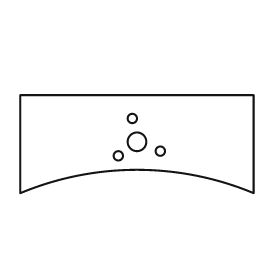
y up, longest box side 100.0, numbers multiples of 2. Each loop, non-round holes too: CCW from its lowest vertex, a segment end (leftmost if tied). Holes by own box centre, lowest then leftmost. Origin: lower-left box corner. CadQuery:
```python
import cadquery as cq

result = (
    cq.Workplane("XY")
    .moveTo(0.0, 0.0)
    .threePointArc((50.0, 10.0), (100.0, 0.0))
    .lineTo(100.0, 42.0)
    .lineTo(0.0, 42.0)
    .close()
    .moveTo(42.0, 16.0)
    .circle(2.0)
    .moveTo(60.0, 18.0)
    .circle(2.0)
    .moveTo(50.0, 22.0)
    .circle(4.0)
    .moveTo(48.0, 32.0)
    .circle(2.0)
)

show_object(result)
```